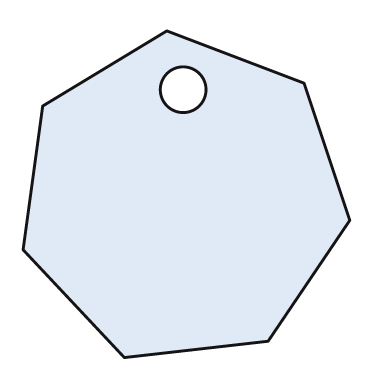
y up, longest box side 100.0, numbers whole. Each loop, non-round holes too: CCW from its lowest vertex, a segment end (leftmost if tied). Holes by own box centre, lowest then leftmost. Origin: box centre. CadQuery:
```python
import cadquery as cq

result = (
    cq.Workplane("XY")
    .moveTo(-19.0, -50.0)
    .lineTo(25.0, -45.0)
    .lineTo(50.0, -8.0)
    .lineTo(36.0, 34.0)
    .lineTo(-6.0, 50.0)
    .lineTo(-44.0, 27.0)
    .lineTo(-50.0, -17.0)
    .close()
    .moveTo(-1.0, 32.0)
    .circle(7.0)
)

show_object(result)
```